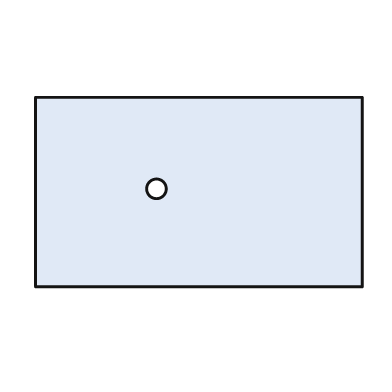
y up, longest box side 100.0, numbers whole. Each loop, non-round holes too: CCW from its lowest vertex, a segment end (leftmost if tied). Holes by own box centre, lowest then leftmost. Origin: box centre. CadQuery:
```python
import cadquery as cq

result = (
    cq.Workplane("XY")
    .moveTo(-50.0, -29.0)
    .lineTo(50.0, -29.0)
    .lineTo(50.0, 29.0)
    .lineTo(-50.0, 29.0)
    .close()
    .moveTo(-13.0, 1.0)
    .circle(3.0)
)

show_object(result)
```